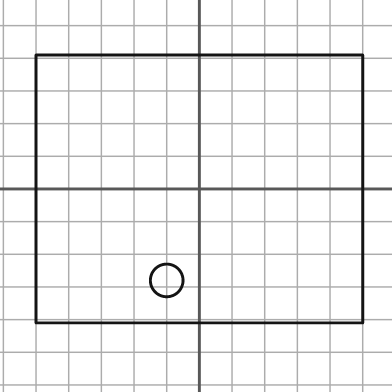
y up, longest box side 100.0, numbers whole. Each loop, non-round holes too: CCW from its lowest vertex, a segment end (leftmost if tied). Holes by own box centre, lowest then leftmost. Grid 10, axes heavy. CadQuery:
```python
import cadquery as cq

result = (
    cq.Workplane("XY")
    .moveTo(-50.0, -41.0)
    .lineTo(50.0, -41.0)
    .lineTo(50.0, 41.0)
    .lineTo(-50.0, 41.0)
    .close()
    .moveTo(-10.0, -28.0)
    .circle(5.0)
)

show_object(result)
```